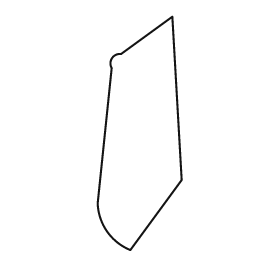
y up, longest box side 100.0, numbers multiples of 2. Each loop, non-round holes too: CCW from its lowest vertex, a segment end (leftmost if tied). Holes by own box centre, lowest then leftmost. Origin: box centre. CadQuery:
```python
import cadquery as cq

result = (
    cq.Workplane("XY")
    .moveTo(-4.0, -50.0)
    .lineTo(18.0, -20.0)
    .lineTo(14.0, 50.0)
    .lineTo(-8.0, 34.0)
    .threePointArc((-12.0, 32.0), (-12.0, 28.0))
    .lineTo(-18.0, -30.0)
    .threePointArc((-14.0, -42.0), (-4.0, -50.0))
    .close()
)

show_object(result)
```